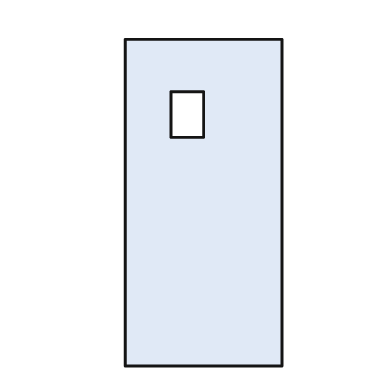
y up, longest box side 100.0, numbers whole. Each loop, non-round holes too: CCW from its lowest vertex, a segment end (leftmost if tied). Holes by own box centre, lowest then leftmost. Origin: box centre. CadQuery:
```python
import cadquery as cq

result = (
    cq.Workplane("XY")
    .moveTo(-24.0, -50.0)
    .lineTo(24.0, -50.0)
    .lineTo(24.0, 50.0)
    .lineTo(-24.0, 50.0)
    .close()
    .moveTo(-10.0, 20.0)
    .lineTo(0.0, 20.0)
    .lineTo(0.0, 34.0)
    .lineTo(-10.0, 34.0)
    .close()
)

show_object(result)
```